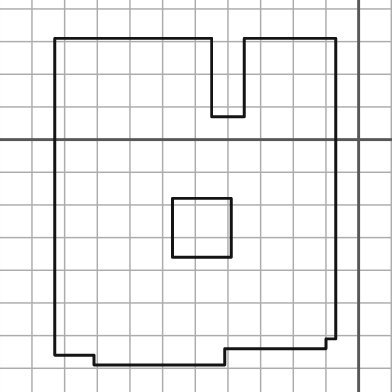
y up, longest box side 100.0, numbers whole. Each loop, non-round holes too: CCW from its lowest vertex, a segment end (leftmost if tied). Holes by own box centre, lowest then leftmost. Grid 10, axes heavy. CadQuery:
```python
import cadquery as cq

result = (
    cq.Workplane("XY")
    .moveTo(-81.0, -69.0)
    .lineTo(-41.0, -69.0)
    .lineTo(-41.0, -64.0)
    .lineTo(-10.0, -64.0)
    .lineTo(-10.0, -61.0)
    .lineTo(-7.0, -61.0)
    .lineTo(-7.0, 31.0)
    .lineTo(-35.0, 31.0)
    .lineTo(-35.0, 7.0)
    .lineTo(-45.0, 7.0)
    .lineTo(-45.0, 31.0)
    .lineTo(-93.0, 31.0)
    .lineTo(-93.0, -66.0)
    .lineTo(-81.0, -66.0)
    .close()
    .moveTo(-57.0, -36.0)
    .lineTo(-39.0, -36.0)
    .lineTo(-39.0, -18.0)
    .lineTo(-57.0, -18.0)
    .close()
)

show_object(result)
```